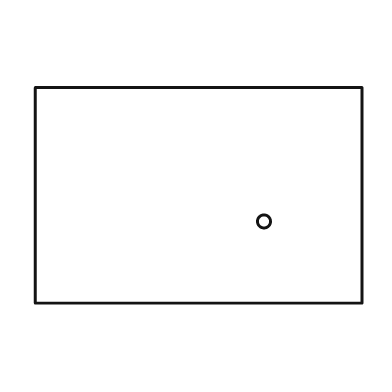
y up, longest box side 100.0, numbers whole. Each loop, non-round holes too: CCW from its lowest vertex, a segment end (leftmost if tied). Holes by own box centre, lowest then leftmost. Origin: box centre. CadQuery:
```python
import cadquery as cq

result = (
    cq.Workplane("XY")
    .moveTo(-50.0, -33.0)
    .lineTo(50.0, -33.0)
    .lineTo(50.0, 33.0)
    .lineTo(-50.0, 33.0)
    .close()
    .moveTo(20.0, -8.0)
    .circle(2.0)
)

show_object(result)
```